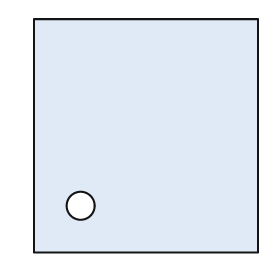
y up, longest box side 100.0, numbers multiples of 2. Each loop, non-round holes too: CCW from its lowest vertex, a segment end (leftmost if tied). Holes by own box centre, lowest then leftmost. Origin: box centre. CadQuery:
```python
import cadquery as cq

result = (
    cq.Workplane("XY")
    .moveTo(-48.0, -50.0)
    .lineTo(48.0, -50.0)
    .lineTo(48.0, 50.0)
    .lineTo(-48.0, 50.0)
    .close()
    .moveTo(-28.0, -30.0)
    .circle(6.0)
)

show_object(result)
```